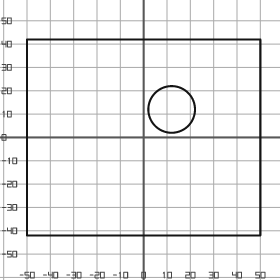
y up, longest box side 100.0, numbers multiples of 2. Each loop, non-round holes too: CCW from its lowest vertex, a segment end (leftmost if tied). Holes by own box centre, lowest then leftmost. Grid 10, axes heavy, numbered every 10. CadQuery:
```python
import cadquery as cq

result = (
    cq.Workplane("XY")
    .moveTo(-50.0, -42.0)
    .lineTo(50.0, -42.0)
    .lineTo(50.0, 42.0)
    .lineTo(-50.0, 42.0)
    .close()
    .moveTo(12.0, 12.0)
    .circle(10.0)
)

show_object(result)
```